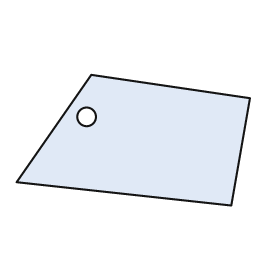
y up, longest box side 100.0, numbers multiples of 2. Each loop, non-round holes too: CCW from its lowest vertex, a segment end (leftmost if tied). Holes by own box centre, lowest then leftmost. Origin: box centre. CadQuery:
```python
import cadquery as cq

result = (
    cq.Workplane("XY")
    .moveTo(42.0, -28.0)
    .lineTo(50.0, 18.0)
    .lineTo(-18.0, 28.0)
    .lineTo(-50.0, -18.0)
    .close()
    .moveTo(-20.0, 10.0)
    .circle(4.0)
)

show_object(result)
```